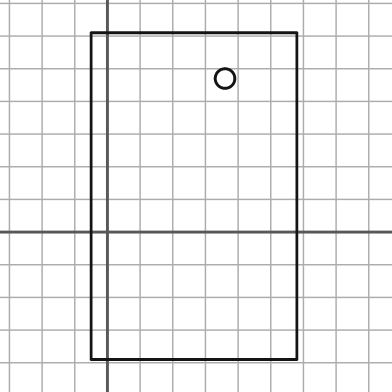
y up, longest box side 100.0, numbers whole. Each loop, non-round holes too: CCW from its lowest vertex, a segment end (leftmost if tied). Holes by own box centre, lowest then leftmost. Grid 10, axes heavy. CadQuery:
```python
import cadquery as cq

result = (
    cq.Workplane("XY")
    .moveTo(-5.0, -39.0)
    .lineTo(58.0, -39.0)
    .lineTo(58.0, 61.0)
    .lineTo(-5.0, 61.0)
    .close()
    .moveTo(36.0, 47.0)
    .circle(3.0)
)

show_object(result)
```